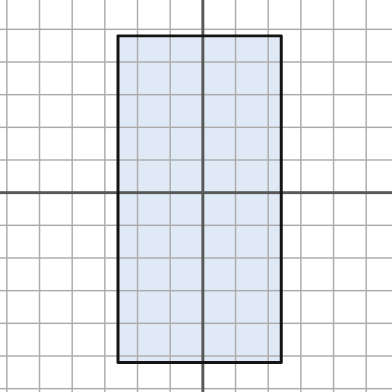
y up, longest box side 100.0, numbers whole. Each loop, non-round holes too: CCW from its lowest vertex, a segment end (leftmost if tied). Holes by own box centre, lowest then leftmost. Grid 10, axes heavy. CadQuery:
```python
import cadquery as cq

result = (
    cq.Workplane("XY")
    .moveTo(-26.0, -52.0)
    .lineTo(24.0, -52.0)
    .lineTo(24.0, 48.0)
    .lineTo(-26.0, 48.0)
    .close()
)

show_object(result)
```